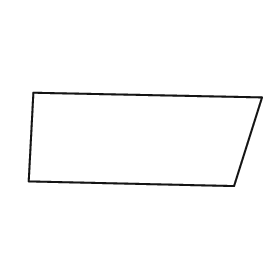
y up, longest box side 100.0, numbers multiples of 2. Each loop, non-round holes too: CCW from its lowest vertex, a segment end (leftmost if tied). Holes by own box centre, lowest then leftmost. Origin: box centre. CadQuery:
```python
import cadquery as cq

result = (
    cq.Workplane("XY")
    .moveTo(38.0, -20.0)
    .lineTo(50.0, 18.0)
    .lineTo(-48.0, 20.0)
    .lineTo(-50.0, -18.0)
    .close()
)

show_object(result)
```